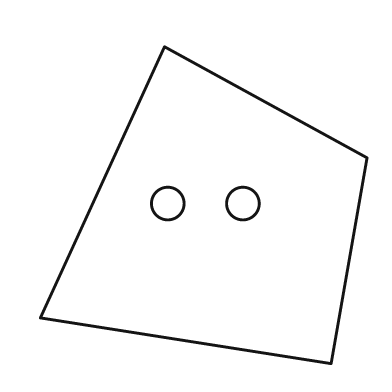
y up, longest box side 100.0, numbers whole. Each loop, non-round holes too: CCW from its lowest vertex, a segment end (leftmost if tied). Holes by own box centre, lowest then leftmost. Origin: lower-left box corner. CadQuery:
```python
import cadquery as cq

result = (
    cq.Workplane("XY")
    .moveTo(89.0, 0.0)
    .lineTo(100.0, 63.0)
    .lineTo(38.0, 97.0)
    .lineTo(0.0, 14.0)
    .close()
    .moveTo(39.0, 49.0)
    .circle(5.0)
    .moveTo(62.0, 49.0)
    .circle(5.0)
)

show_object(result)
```